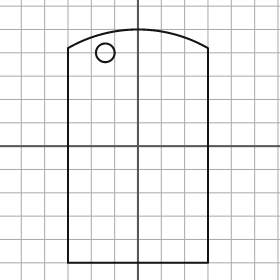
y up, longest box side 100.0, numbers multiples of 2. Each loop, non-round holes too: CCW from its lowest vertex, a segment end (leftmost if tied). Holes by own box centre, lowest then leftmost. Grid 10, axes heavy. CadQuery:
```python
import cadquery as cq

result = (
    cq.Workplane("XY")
    .moveTo(-30.0, -50.0)
    .lineTo(30.0, -50.0)
    .lineTo(30.0, 42.0)
    .threePointArc((0.0, 50.0), (-30.0, 42.0))
    .close()
    .moveTo(-14.0, 40.0)
    .circle(4.0)
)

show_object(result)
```